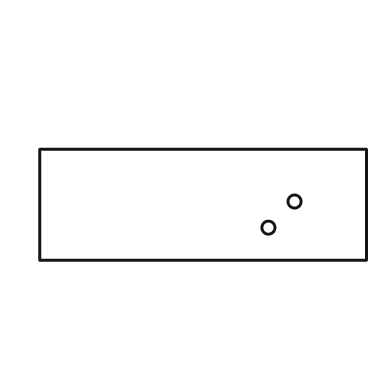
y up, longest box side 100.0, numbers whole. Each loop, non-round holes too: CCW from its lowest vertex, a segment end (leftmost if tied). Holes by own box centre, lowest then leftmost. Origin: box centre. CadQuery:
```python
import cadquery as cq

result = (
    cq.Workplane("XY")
    .moveTo(-50.0, -17.0)
    .lineTo(50.0, -17.0)
    .lineTo(50.0, 17.0)
    .lineTo(-50.0, 17.0)
    .close()
    .moveTo(20.0, -7.0)
    .circle(2.0)
    .moveTo(28.0, 1.0)
    .circle(2.0)
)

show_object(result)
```